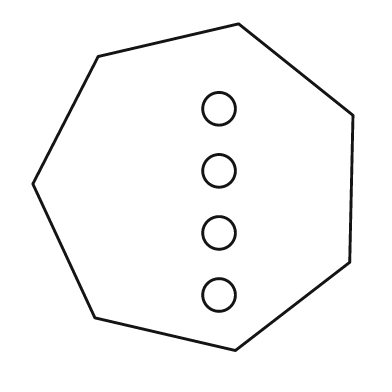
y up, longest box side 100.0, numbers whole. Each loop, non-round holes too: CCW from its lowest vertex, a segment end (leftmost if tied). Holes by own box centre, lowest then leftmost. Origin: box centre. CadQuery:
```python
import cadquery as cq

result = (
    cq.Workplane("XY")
    .moveTo(13.0, -50.0)
    .lineTo(48.0, -23.0)
    .lineTo(49.0, 22.0)
    .lineTo(14.0, 50.0)
    .lineTo(-29.0, 40.0)
    .lineTo(-49.0, 1.0)
    .lineTo(-30.0, -40.0)
    .close()
    .moveTo(8.0, -33.0)
    .circle(5.0)
    .moveTo(8.0, -14.0)
    .circle(5.0)
    .moveTo(8.0, 5.0)
    .circle(5.0)
    .moveTo(8.0, 24.0)
    .circle(5.0)
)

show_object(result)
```